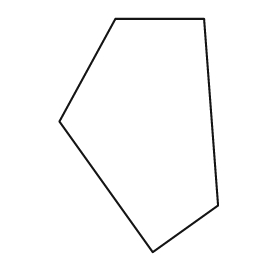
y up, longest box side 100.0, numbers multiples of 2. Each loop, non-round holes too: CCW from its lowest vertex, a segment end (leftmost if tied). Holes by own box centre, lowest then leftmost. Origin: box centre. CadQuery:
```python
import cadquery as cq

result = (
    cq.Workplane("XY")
    .moveTo(6.0, -50.0)
    .lineTo(34.0, -30.0)
    .lineTo(28.0, 50.0)
    .lineTo(-10.0, 50.0)
    .lineTo(-34.0, 6.0)
    .close()
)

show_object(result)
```